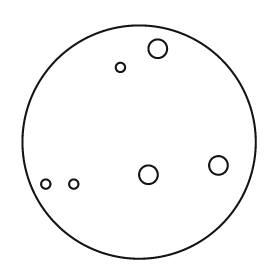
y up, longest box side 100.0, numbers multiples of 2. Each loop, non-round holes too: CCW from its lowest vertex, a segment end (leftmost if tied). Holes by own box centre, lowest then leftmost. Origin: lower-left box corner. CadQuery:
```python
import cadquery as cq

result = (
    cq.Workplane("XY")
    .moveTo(50.0, 50.0)
    .circle(50.0)
    .moveTo(10.0, 32.0)
    .circle(2.0)
    .moveTo(22.0, 32.0)
    .circle(2.0)
    .moveTo(54.0, 36.0)
    .circle(4.0)
    .moveTo(84.0, 40.0)
    .circle(4.0)
    .moveTo(42.0, 82.0)
    .circle(2.0)
    .moveTo(58.0, 90.0)
    .circle(4.0)
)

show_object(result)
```